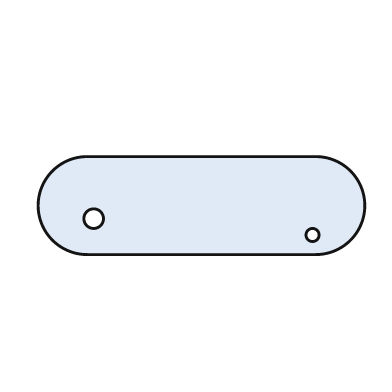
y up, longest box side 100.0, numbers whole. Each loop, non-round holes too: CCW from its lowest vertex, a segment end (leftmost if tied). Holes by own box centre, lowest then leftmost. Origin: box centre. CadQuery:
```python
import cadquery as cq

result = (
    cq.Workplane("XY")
    .moveTo(-35.0, -15.0)
    .lineTo(35.0, -15.0)
    .threePointArc((50.0, 0.0), (35.0, 15.0))
    .lineTo(-35.0, 15.0)
    .threePointArc((-50.0, 0.0), (-35.0, -15.0))
    .close()
    .moveTo(34.0, -9.0)
    .circle(2.0)
    .moveTo(-33.0, -4.0)
    .circle(3.0)
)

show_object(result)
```